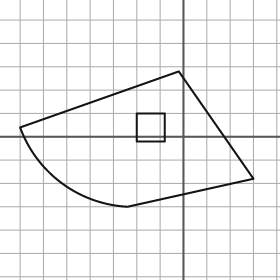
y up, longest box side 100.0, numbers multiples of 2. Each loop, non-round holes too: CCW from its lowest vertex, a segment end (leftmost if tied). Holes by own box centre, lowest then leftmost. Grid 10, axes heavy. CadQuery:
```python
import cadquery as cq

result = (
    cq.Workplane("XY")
    .moveTo(-24.0, -30.0)
    .lineTo(30.0, -18.0)
    .lineTo(-2.0, 28.0)
    .lineTo(-70.0, 4.0)
    .threePointArc((-52.0, -20.0), (-24.0, -30.0))
    .close()
    .moveTo(-20.0, -2.0)
    .lineTo(-8.0, -2.0)
    .lineTo(-8.0, 10.0)
    .lineTo(-20.0, 10.0)
    .close()
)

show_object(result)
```